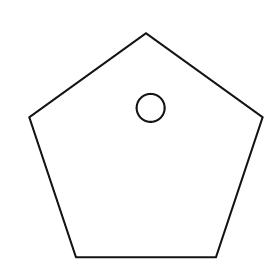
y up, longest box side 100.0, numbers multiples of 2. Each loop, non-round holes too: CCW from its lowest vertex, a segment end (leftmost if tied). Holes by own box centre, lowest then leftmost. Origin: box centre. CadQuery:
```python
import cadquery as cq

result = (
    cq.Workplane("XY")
    .moveTo(-30.0, -48.0)
    .lineTo(30.0, -48.0)
    .lineTo(50.0, 12.0)
    .lineTo(0.0, 48.0)
    .lineTo(-50.0, 12.0)
    .close()
    .moveTo(2.0, 16.0)
    .circle(6.0)
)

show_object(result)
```